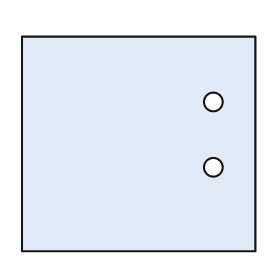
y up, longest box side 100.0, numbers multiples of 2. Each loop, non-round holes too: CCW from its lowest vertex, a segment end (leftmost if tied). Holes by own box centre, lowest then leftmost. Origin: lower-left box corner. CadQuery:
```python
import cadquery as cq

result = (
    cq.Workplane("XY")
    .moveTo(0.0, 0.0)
    .lineTo(100.0, 0.0)
    .lineTo(100.0, 92.0)
    .lineTo(0.0, 92.0)
    .close()
    .moveTo(82.0, 36.0)
    .circle(4.0)
    .moveTo(82.0, 64.0)
    .circle(4.0)
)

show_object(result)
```